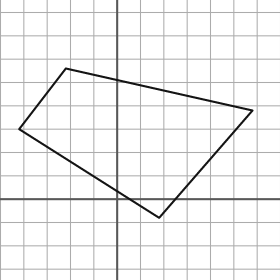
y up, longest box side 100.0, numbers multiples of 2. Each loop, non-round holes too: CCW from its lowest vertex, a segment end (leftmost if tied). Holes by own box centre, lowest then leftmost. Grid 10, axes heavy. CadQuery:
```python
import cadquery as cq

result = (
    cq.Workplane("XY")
    .moveTo(18.0, -8.0)
    .lineTo(58.0, 38.0)
    .lineTo(-22.0, 56.0)
    .lineTo(-42.0, 30.0)
    .close()
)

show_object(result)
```